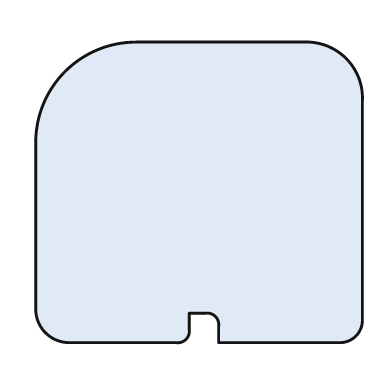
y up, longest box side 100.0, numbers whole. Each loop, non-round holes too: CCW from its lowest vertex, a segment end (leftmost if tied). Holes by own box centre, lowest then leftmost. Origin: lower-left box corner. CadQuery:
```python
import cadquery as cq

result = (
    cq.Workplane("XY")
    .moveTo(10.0, 0.0)
    .lineTo(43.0, 0.0)
    .threePointArc((46.0, 1.0), (47.0, 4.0))
    .lineTo(47.0, 9.0)
    .lineTo(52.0, 9.0)
    .threePointArc((55.0, 8.0), (56.0, 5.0))
    .lineTo(56.0, 0.0)
    .lineTo(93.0, 0.0)
    .threePointArc((98.0, 2.0), (100.0, 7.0))
    .lineTo(100.0, 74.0)
    .threePointArc((95.0, 87.0), (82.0, 92.0))
    .lineTo(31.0, 92.0)
    .threePointArc((9.0, 83.0), (0.0, 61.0))
    .lineTo(0.0, 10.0)
    .threePointArc((3.0, 3.0), (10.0, 0.0))
    .close()
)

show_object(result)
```